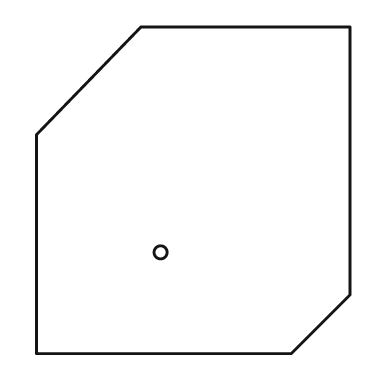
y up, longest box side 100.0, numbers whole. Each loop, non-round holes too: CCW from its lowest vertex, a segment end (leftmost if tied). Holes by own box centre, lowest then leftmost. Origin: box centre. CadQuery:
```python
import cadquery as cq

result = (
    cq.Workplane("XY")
    .moveTo(-48.0, -50.0)
    .lineTo(30.0, -50.0)
    .lineTo(48.0, -32.0)
    .lineTo(48.0, 50.0)
    .lineTo(-16.0, 50.0)
    .lineTo(-48.0, 17.0)
    .close()
    .moveTo(-10.0, -19.0)
    .circle(2.0)
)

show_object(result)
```